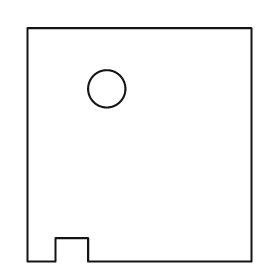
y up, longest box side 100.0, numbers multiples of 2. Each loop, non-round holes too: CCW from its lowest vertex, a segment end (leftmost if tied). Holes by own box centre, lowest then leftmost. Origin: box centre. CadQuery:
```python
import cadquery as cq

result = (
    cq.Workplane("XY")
    .moveTo(-48.0, -50.0)
    .lineTo(-36.0, -50.0)
    .lineTo(-36.0, -40.0)
    .lineTo(-22.0, -40.0)
    .lineTo(-22.0, -50.0)
    .lineTo(48.0, -50.0)
    .lineTo(48.0, 50.0)
    .lineTo(-48.0, 50.0)
    .close()
    .moveTo(-14.0, 24.0)
    .circle(8.0)
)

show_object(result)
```